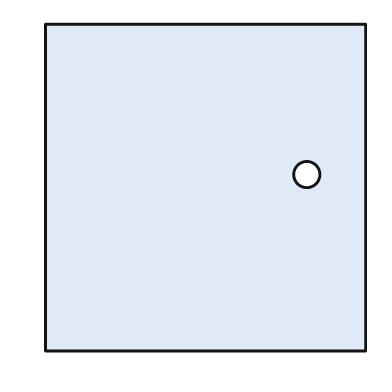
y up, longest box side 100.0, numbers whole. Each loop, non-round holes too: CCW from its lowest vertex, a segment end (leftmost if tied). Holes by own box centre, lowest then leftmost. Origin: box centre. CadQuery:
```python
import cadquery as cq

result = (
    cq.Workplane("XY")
    .moveTo(-49.0, -50.0)
    .lineTo(49.0, -50.0)
    .lineTo(49.0, 50.0)
    .lineTo(-49.0, 50.0)
    .close()
    .moveTo(31.0, 4.0)
    .circle(4.0)
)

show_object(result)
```